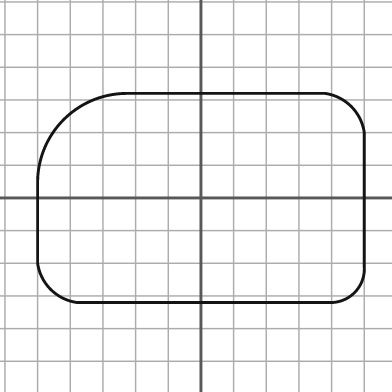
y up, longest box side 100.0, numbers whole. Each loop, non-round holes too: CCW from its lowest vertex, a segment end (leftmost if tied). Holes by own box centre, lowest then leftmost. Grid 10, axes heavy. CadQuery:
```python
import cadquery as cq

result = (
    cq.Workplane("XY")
    .moveTo(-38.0, -32.0)
    .lineTo(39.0, -32.0)
    .threePointArc((47.0, -29.0), (50.0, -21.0))
    .lineTo(50.0, 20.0)
    .threePointArc((46.0, 28.0), (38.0, 32.0))
    .lineTo(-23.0, 32.0)
    .threePointArc((-42.0, 24.0), (-50.0, 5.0))
    .lineTo(-50.0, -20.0)
    .threePointArc((-46.0, -28.0), (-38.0, -32.0))
    .close()
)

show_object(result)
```